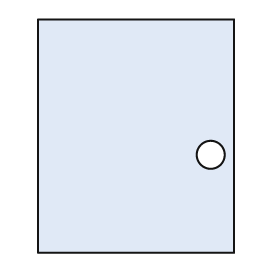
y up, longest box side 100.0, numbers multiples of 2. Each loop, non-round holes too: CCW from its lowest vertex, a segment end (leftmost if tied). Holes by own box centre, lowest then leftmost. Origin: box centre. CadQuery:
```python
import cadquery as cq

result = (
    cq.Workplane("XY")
    .moveTo(-42.0, -50.0)
    .lineTo(42.0, -50.0)
    .lineTo(42.0, 50.0)
    .lineTo(-42.0, 50.0)
    .close()
    .moveTo(32.0, -8.0)
    .circle(6.0)
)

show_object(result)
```